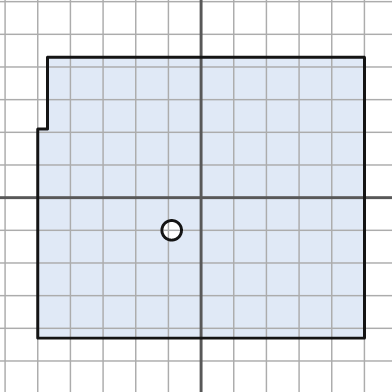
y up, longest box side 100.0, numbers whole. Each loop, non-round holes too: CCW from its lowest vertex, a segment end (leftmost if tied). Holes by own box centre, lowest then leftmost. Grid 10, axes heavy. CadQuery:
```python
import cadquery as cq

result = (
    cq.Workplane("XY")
    .moveTo(-50.0, -43.0)
    .lineTo(50.0, -43.0)
    .lineTo(50.0, 43.0)
    .lineTo(-47.0, 43.0)
    .lineTo(-47.0, 21.0)
    .lineTo(-50.0, 21.0)
    .close()
    .moveTo(-9.0, -10.0)
    .circle(3.0)
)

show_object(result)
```